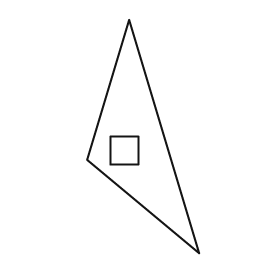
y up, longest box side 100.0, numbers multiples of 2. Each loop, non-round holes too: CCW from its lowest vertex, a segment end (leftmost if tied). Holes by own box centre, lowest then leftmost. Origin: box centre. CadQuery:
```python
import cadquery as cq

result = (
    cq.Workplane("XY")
    .moveTo(24.0, -50.0)
    .lineTo(-6.0, 50.0)
    .lineTo(-24.0, -10.0)
    .close()
    .moveTo(-14.0, -12.0)
    .lineTo(-2.0, -12.0)
    .lineTo(-2.0, 0.0)
    .lineTo(-14.0, 0.0)
    .close()
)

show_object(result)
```